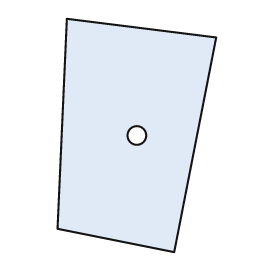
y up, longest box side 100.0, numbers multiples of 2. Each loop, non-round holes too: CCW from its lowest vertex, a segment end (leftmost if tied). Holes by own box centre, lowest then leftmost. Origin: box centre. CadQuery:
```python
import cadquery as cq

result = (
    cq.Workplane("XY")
    .moveTo(16.0, -50.0)
    .lineTo(34.0, 42.0)
    .lineTo(-30.0, 50.0)
    .lineTo(-34.0, -40.0)
    .close()
    .moveTo(0.0, 0.0)
    .circle(4.0)
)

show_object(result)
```